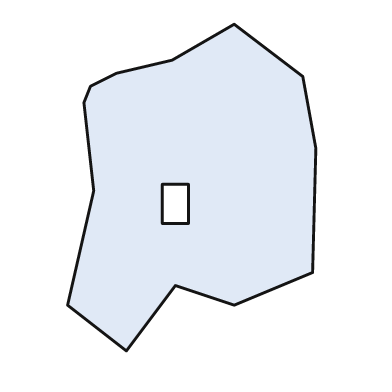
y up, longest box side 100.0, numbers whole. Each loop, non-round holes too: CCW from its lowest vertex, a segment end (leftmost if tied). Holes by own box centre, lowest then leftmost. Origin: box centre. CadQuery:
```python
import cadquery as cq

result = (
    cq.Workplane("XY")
    .moveTo(-20.0, -50.0)
    .lineTo(-5.0, -30.0)
    .lineTo(13.0, -36.0)
    .lineTo(37.0, -26.0)
    .lineTo(38.0, 12.0)
    .lineTo(34.0, 34.0)
    .lineTo(13.0, 50.0)
    .lineTo(-6.0, 39.0)
    .lineTo(-23.0, 35.0)
    .lineTo(-31.0, 31.0)
    .lineTo(-33.0, 26.0)
    .lineTo(-30.0, -1.0)
    .lineTo(-38.0, -36.0)
    .close()
    .moveTo(-9.0, -11.0)
    .lineTo(-1.0, -11.0)
    .lineTo(-1.0, 1.0)
    .lineTo(-9.0, 1.0)
    .close()
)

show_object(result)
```